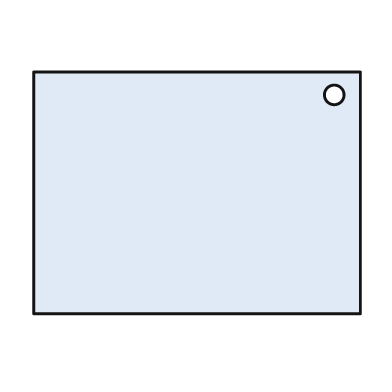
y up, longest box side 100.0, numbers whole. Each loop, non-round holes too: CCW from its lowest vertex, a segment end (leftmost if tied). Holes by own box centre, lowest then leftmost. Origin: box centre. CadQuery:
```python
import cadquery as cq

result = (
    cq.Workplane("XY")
    .moveTo(-50.0, -37.0)
    .lineTo(50.0, -37.0)
    .lineTo(50.0, 37.0)
    .lineTo(-50.0, 37.0)
    .close()
    .moveTo(42.0, 30.0)
    .circle(3.0)
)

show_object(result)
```